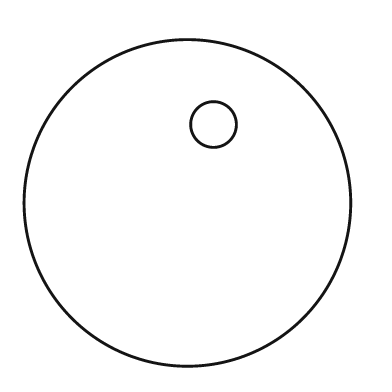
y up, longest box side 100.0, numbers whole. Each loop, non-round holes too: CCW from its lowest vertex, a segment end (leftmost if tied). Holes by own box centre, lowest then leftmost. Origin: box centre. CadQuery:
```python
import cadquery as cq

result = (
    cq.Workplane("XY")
    .moveTo(0.0, 0.0)
    .circle(50.0)
    .moveTo(8.0, 24.0)
    .circle(7.0)
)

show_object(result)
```